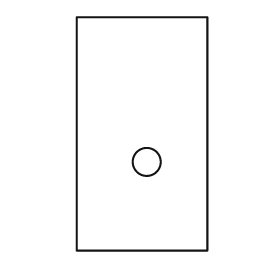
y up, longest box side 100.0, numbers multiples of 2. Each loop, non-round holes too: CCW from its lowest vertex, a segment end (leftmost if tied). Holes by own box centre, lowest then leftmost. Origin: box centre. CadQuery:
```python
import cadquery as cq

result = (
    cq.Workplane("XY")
    .moveTo(-28.0, -50.0)
    .lineTo(28.0, -50.0)
    .lineTo(28.0, 50.0)
    .lineTo(-28.0, 50.0)
    .close()
    .moveTo(2.0, -12.0)
    .circle(6.0)
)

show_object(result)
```